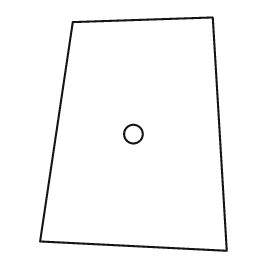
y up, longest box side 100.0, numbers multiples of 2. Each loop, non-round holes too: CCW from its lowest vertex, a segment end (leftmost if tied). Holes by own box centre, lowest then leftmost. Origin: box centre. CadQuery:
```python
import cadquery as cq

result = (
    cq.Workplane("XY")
    .moveTo(40.0, -50.0)
    .lineTo(34.0, 50.0)
    .lineTo(-26.0, 48.0)
    .lineTo(-40.0, -46.0)
    .close()
    .moveTo(0.0, 0.0)
    .circle(4.0)
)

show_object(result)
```